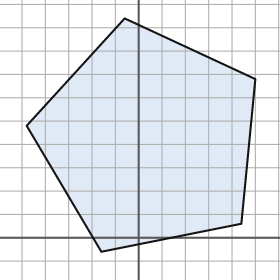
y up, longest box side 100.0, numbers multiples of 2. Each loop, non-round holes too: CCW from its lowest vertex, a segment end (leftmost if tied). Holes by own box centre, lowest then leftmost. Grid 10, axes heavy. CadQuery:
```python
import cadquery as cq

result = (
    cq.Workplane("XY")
    .moveTo(-16.0, -6.0)
    .lineTo(44.0, 6.0)
    .lineTo(50.0, 68.0)
    .lineTo(-6.0, 94.0)
    .lineTo(-48.0, 48.0)
    .close()
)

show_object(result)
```